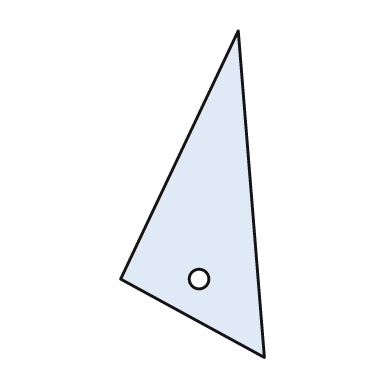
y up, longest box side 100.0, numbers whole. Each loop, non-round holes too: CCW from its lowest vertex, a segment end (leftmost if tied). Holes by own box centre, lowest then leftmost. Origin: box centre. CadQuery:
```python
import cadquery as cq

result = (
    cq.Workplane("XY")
    .moveTo(22.0, -50.0)
    .lineTo(14.0, 50.0)
    .lineTo(-22.0, -26.0)
    .close()
    .moveTo(2.0, -26.0)
    .circle(3.0)
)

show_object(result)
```